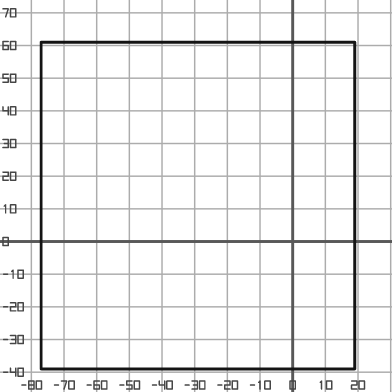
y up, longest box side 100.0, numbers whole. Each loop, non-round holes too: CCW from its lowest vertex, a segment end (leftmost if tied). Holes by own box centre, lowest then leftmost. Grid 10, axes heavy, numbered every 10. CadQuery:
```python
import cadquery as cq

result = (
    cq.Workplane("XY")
    .moveTo(-77.0, -39.0)
    .lineTo(19.0, -39.0)
    .lineTo(19.0, 61.0)
    .lineTo(-77.0, 61.0)
    .close()
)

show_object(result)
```